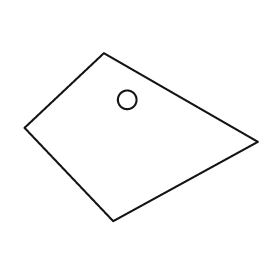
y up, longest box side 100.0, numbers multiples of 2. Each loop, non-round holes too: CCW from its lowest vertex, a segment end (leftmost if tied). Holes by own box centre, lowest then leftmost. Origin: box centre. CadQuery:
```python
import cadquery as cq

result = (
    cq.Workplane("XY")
    .moveTo(-12.0, -36.0)
    .lineTo(50.0, -2.0)
    .lineTo(-16.0, 36.0)
    .lineTo(-50.0, 4.0)
    .close()
    .moveTo(-6.0, 16.0)
    .circle(4.0)
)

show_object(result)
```